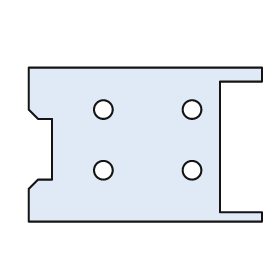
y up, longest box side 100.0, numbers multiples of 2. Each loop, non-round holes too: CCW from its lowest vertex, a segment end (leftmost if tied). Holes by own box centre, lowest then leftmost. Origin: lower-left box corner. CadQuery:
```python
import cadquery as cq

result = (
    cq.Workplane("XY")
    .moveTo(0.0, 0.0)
    .lineTo(100.0, 0.0)
    .lineTo(100.0, 4.0)
    .lineTo(82.0, 4.0)
    .lineTo(82.0, 60.0)
    .lineTo(100.0, 60.0)
    .lineTo(100.0, 66.0)
    .lineTo(0.0, 66.0)
    .lineTo(0.0, 48.0)
    .lineTo(4.0, 44.0)
    .lineTo(10.0, 44.0)
    .lineTo(10.0, 18.0)
    .lineTo(4.0, 18.0)
    .lineTo(0.0, 14.0)
    .close()
    .moveTo(32.0, 22.0)
    .circle(4.0)
    .moveTo(70.0, 22.0)
    .circle(4.0)
    .moveTo(32.0, 48.0)
    .circle(4.0)
    .moveTo(70.0, 48.0)
    .circle(4.0)
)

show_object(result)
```